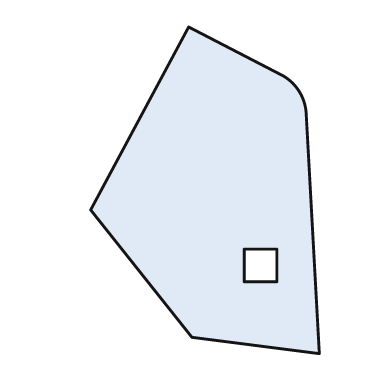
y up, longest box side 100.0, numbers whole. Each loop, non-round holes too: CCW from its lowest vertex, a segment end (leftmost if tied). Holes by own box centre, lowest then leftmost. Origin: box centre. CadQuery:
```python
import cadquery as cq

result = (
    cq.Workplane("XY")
    .moveTo(35.0, -50.0)
    .lineTo(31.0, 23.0)
    .threePointArc((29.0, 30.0), (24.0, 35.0))
    .lineTo(-5.0, 50.0)
    .lineTo(-35.0, -6.0)
    .lineTo(-4.0, -45.0)
    .close()
    .moveTo(12.0, -28.0)
    .lineTo(22.0, -28.0)
    .lineTo(22.0, -18.0)
    .lineTo(12.0, -18.0)
    .close()
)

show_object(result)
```